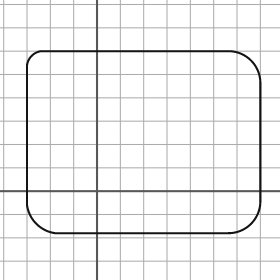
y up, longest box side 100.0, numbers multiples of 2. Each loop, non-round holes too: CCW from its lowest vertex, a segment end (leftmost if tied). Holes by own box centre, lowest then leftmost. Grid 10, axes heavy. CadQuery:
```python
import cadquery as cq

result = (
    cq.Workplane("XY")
    .moveTo(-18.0, -18.0)
    .lineTo(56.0, -18.0)
    .threePointArc((66.0, -14.0), (70.0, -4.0))
    .lineTo(70.0, 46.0)
    .threePointArc((66.0, 56.0), (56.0, 60.0))
    .lineTo(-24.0, 60.0)
    .threePointArc((-28.0, 58.0), (-30.0, 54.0))
    .lineTo(-30.0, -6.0)
    .threePointArc((-26.0, -14.0), (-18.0, -18.0))
    .close()
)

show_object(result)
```